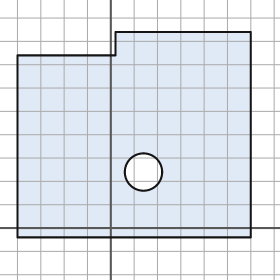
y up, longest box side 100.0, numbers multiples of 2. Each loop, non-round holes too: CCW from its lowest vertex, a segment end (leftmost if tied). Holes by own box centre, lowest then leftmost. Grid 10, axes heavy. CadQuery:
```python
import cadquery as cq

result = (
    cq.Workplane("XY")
    .moveTo(-40.0, -4.0)
    .lineTo(60.0, -4.0)
    .lineTo(60.0, 84.0)
    .lineTo(2.0, 84.0)
    .lineTo(2.0, 74.0)
    .lineTo(-40.0, 74.0)
    .close()
    .moveTo(14.0, 24.0)
    .circle(8.0)
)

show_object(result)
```